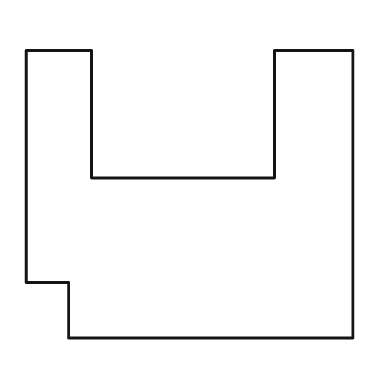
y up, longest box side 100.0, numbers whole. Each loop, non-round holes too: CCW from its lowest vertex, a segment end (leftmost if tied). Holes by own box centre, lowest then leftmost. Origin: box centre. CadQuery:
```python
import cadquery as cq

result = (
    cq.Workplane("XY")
    .moveTo(-37.0, -44.0)
    .lineTo(50.0, -44.0)
    .lineTo(50.0, 44.0)
    .lineTo(26.0, 44.0)
    .lineTo(26.0, 5.0)
    .lineTo(-30.0, 5.0)
    .lineTo(-30.0, 44.0)
    .lineTo(-50.0, 44.0)
    .lineTo(-50.0, -27.0)
    .lineTo(-37.0, -27.0)
    .close()
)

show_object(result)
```